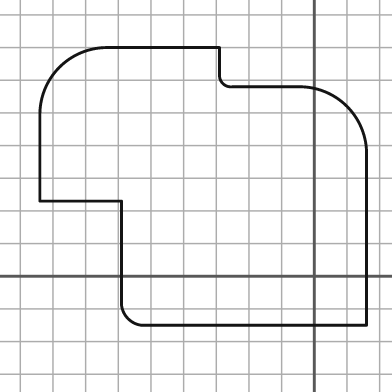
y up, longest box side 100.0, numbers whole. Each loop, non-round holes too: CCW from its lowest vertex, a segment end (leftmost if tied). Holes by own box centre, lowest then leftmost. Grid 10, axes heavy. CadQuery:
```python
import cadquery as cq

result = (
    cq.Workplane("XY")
    .moveTo(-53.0, -15.0)
    .lineTo(16.0, -15.0)
    .lineTo(16.0, 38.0)
    .threePointArc((10.0, 52.0), (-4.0, 58.0))
    .lineTo(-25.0, 58.0)
    .threePointArc((-28.0, 59.0), (-29.0, 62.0))
    .lineTo(-29.0, 70.0)
    .lineTo(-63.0, 70.0)
    .threePointArc((-78.0, 64.0), (-84.0, 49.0))
    .lineTo(-84.0, 23.0)
    .lineTo(-59.0, 23.0)
    .lineTo(-59.0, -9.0)
    .threePointArc((-57.0, -13.0), (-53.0, -15.0))
    .close()
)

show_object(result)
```